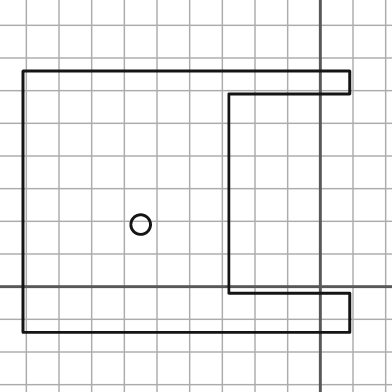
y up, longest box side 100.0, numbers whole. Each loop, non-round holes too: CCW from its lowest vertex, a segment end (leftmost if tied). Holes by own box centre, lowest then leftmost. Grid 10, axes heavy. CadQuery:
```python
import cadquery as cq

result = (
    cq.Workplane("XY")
    .moveTo(-91.0, -14.0)
    .lineTo(9.0, -14.0)
    .lineTo(9.0, -2.0)
    .lineTo(-28.0, -2.0)
    .lineTo(-28.0, 59.0)
    .lineTo(9.0, 59.0)
    .lineTo(9.0, 66.0)
    .lineTo(-91.0, 66.0)
    .close()
    .moveTo(-55.0, 19.0)
    .circle(3.0)
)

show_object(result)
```